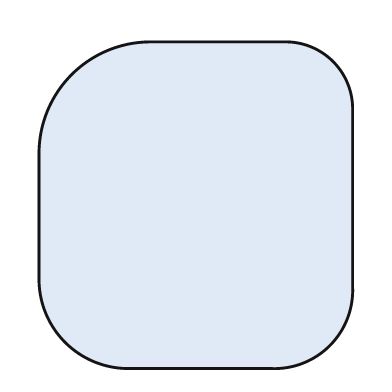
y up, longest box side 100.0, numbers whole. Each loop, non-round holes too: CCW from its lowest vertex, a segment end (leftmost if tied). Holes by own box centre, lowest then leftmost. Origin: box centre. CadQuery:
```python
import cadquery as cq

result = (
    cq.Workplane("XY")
    .moveTo(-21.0, -50.0)
    .lineTo(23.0, -50.0)
    .threePointArc((41.0, -43.0), (48.0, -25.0))
    .lineTo(48.0, 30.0)
    .threePointArc((42.0, 44.0), (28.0, 50.0))
    .lineTo(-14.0, 50.0)
    .threePointArc((-38.0, 40.0), (-48.0, 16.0))
    .lineTo(-48.0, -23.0)
    .threePointArc((-40.0, -42.0), (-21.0, -50.0))
    .close()
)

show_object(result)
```